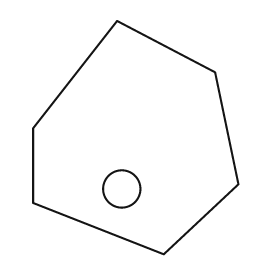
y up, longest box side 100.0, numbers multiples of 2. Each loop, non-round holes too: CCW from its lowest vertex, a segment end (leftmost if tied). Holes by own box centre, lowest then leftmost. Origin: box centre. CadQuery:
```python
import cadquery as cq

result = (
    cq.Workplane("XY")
    .moveTo(12.0, -50.0)
    .lineTo(44.0, -20.0)
    .lineTo(34.0, 28.0)
    .lineTo(-8.0, 50.0)
    .lineTo(-44.0, 4.0)
    .lineTo(-44.0, -28.0)
    .close()
    .moveTo(-6.0, -22.0)
    .circle(8.0)
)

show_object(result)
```